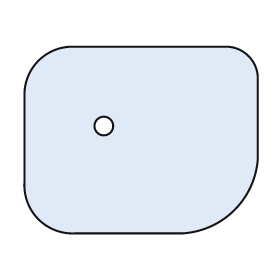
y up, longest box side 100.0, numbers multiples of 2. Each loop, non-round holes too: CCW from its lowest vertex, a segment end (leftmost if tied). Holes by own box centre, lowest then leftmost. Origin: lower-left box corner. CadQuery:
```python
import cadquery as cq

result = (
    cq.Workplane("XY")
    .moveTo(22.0, 0.0)
    .lineTo(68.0, 0.0)
    .threePointArc((90.0, 10.0), (100.0, 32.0))
    .lineTo(100.0, 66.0)
    .threePointArc((96.0, 76.0), (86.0, 80.0))
    .lineTo(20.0, 80.0)
    .threePointArc((6.0, 74.0), (0.0, 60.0))
    .lineTo(0.0, 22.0)
    .threePointArc((6.0, 6.0), (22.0, 0.0))
    .close()
    .moveTo(34.0, 46.0)
    .circle(4.0)
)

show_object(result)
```